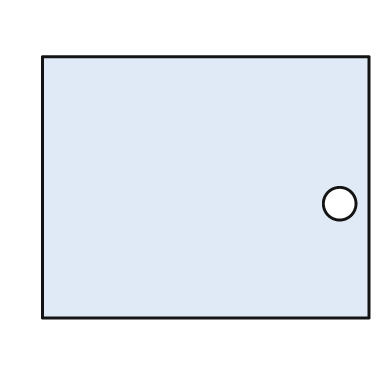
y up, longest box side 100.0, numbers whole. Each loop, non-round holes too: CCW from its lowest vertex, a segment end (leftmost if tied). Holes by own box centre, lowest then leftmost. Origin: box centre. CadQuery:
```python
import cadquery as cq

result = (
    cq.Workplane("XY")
    .moveTo(-50.0, -40.0)
    .lineTo(50.0, -40.0)
    .lineTo(50.0, 40.0)
    .lineTo(-50.0, 40.0)
    .close()
    .moveTo(41.0, -5.0)
    .circle(5.0)
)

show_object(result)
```